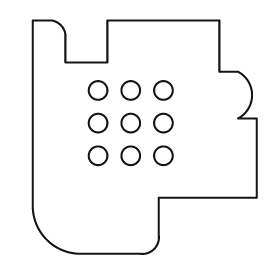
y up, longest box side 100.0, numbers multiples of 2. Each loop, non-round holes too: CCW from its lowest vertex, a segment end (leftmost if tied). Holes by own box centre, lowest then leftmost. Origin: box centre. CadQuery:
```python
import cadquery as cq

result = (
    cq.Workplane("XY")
    .moveTo(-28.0, -50.0)
    .lineTo(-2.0, -50.0)
    .threePointArc((4.0, -48.0), (6.0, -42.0))
    .lineTo(6.0, -26.0)
    .lineTo(48.0, -26.0)
    .lineTo(48.0, 8.0)
    .lineTo(40.0, 8.0)
    .threePointArc((46.0, 18.0), (40.0, 28.0))
    .lineTo(32.0, 28.0)
    .lineTo(32.0, 50.0)
    .lineTo(-16.0, 50.0)
    .lineTo(-16.0, 32.0)
    .lineTo(-34.0, 32.0)
    .lineTo(-34.0, 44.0)
    .threePointArc((-36.0, 48.0), (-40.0, 50.0))
    .lineTo(-48.0, 50.0)
    .lineTo(-48.0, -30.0)
    .threePointArc((-42.0, -44.0), (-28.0, -50.0))
    .close()
    .moveTo(-20.0, -8.0)
    .circle(4.0)
    .moveTo(-6.0, -8.0)
    .circle(4.0)
    .moveTo(8.0, -8.0)
    .circle(4.0)
    .moveTo(-20.0, 6.0)
    .circle(4.0)
    .moveTo(-6.0, 6.0)
    .circle(4.0)
    .moveTo(8.0, 6.0)
    .circle(4.0)
    .moveTo(-20.0, 20.0)
    .circle(4.0)
    .moveTo(-6.0, 20.0)
    .circle(4.0)
    .moveTo(8.0, 20.0)
    .circle(4.0)
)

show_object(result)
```